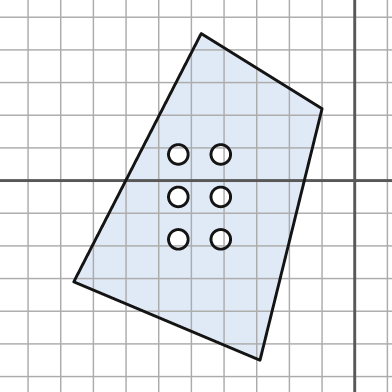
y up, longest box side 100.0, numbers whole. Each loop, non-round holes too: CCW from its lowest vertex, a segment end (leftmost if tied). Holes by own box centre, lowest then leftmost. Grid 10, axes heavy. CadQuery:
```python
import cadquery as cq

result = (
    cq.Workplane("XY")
    .moveTo(-29.0, -55.0)
    .lineTo(-10.0, 22.0)
    .lineTo(-47.0, 45.0)
    .lineTo(-86.0, -31.0)
    .close()
    .moveTo(-54.0, -18.0)
    .circle(3.0)
    .moveTo(-41.0, -18.0)
    .circle(3.0)
    .moveTo(-54.0, -5.0)
    .circle(3.0)
    .moveTo(-41.0, -5.0)
    .circle(3.0)
    .moveTo(-54.0, 8.0)
    .circle(3.0)
    .moveTo(-41.0, 8.0)
    .circle(3.0)
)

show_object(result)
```